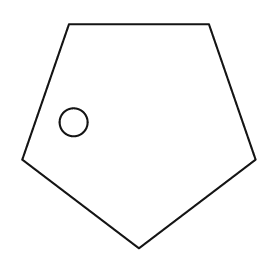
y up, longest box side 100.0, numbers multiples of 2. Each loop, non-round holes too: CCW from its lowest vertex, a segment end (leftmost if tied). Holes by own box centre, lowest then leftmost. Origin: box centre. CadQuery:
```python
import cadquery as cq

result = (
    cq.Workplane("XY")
    .moveTo(0.0, -48.0)
    .lineTo(50.0, -10.0)
    .lineTo(30.0, 48.0)
    .lineTo(-30.0, 48.0)
    .lineTo(-50.0, -10.0)
    .close()
    .moveTo(-28.0, 6.0)
    .circle(6.0)
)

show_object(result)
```